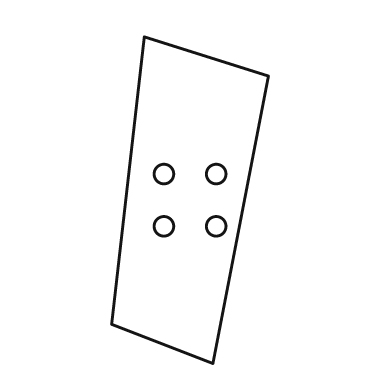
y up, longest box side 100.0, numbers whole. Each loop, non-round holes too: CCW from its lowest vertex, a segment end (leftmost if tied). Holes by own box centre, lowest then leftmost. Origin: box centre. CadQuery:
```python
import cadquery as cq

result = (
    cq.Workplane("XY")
    .moveTo(7.0, -50.0)
    .lineTo(24.0, 38.0)
    .lineTo(-14.0, 50.0)
    .lineTo(-24.0, -38.0)
    .close()
    .moveTo(-8.0, -8.0)
    .circle(3.0)
    .moveTo(8.0, -8.0)
    .circle(3.0)
    .moveTo(-8.0, 8.0)
    .circle(3.0)
    .moveTo(8.0, 8.0)
    .circle(3.0)
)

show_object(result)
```